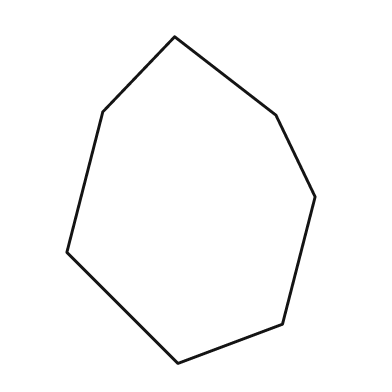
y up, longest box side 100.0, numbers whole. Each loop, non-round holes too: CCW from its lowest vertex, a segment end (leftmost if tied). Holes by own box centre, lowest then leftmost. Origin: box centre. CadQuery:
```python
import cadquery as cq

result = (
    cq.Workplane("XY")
    .moveTo(-4.0, -50.0)
    .lineTo(28.0, -38.0)
    .lineTo(38.0, 1.0)
    .lineTo(26.0, 26.0)
    .lineTo(-5.0, 50.0)
    .lineTo(-27.0, 27.0)
    .lineTo(-38.0, -16.0)
    .close()
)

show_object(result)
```